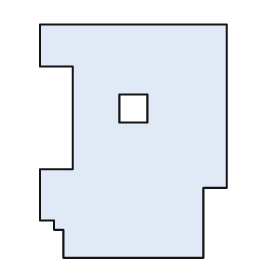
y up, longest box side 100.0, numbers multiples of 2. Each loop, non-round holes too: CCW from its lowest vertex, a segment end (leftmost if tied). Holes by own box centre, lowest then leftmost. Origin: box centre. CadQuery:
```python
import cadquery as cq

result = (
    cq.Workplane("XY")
    .moveTo(-30.0, -50.0)
    .lineTo(30.0, -50.0)
    .lineTo(30.0, -20.0)
    .lineTo(40.0, -20.0)
    .lineTo(40.0, 50.0)
    .lineTo(-40.0, 50.0)
    .lineTo(-40.0, 32.0)
    .lineTo(-26.0, 32.0)
    .lineTo(-26.0, -12.0)
    .lineTo(-40.0, -12.0)
    .lineTo(-40.0, -34.0)
    .lineTo(-34.0, -34.0)
    .lineTo(-34.0, -38.0)
    .lineTo(-30.0, -38.0)
    .close()
    .moveTo(-6.0, 8.0)
    .lineTo(6.0, 8.0)
    .lineTo(6.0, 20.0)
    .lineTo(-6.0, 20.0)
    .close()
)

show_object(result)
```